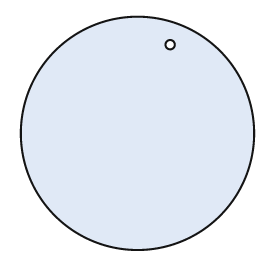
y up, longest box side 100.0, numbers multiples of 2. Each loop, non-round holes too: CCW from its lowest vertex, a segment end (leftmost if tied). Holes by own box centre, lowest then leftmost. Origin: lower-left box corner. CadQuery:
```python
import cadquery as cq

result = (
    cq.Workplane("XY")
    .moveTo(50.0, 50.0)
    .circle(50.0)
    .moveTo(64.0, 88.0)
    .circle(2.0)
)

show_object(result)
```